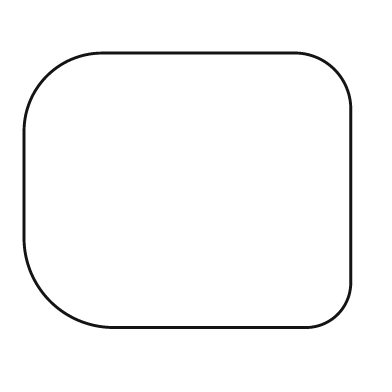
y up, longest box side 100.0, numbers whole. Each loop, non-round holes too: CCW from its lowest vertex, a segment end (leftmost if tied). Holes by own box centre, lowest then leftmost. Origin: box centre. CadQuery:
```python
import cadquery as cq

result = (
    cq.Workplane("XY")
    .moveTo(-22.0, -42.0)
    .lineTo(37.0, -42.0)
    .threePointArc((46.0, -38.0), (50.0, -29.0))
    .lineTo(50.0, 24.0)
    .threePointArc((45.0, 37.0), (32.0, 42.0))
    .lineTo(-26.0, 42.0)
    .threePointArc((-43.0, 35.0), (-50.0, 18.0))
    .lineTo(-50.0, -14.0)
    .threePointArc((-42.0, -34.0), (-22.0, -42.0))
    .close()
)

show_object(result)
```